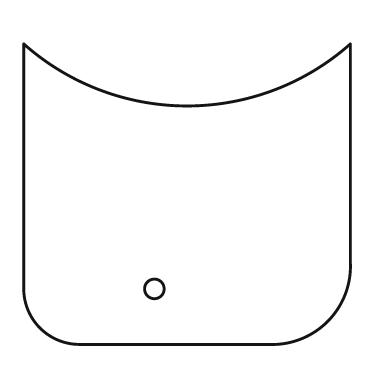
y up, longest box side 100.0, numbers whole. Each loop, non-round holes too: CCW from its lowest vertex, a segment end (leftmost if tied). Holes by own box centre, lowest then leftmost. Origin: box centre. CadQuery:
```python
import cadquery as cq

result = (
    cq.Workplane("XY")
    .moveTo(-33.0, -46.0)
    .lineTo(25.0, -46.0)
    .threePointArc((43.0, -39.0), (50.0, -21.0))
    .lineTo(50.0, 46.0)
    .threePointArc((0.0, 27.0), (-50.0, 46.0))
    .lineTo(-50.0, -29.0)
    .threePointArc((-45.0, -41.0), (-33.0, -46.0))
    .close()
    .moveTo(-10.0, -29.0)
    .circle(3.0)
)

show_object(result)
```